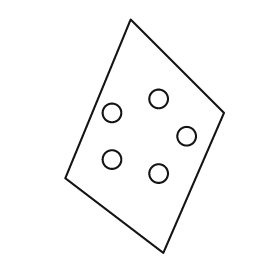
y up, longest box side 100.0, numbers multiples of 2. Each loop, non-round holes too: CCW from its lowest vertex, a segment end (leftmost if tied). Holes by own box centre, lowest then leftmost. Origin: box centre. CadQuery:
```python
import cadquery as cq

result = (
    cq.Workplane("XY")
    .moveTo(8.0, -50.0)
    .lineTo(34.0, 10.0)
    .lineTo(-6.0, 50.0)
    .lineTo(-34.0, -18.0)
    .close()
    .moveTo(6.0, -16.0)
    .circle(4.0)
    .moveTo(-14.0, -10.0)
    .circle(4.0)
    .moveTo(18.0, 0.0)
    .circle(4.0)
    .moveTo(-14.0, 10.0)
    .circle(4.0)
    .moveTo(6.0, 16.0)
    .circle(4.0)
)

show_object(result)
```